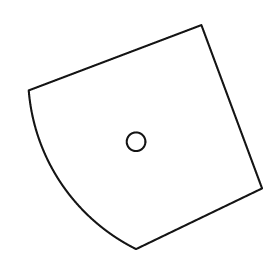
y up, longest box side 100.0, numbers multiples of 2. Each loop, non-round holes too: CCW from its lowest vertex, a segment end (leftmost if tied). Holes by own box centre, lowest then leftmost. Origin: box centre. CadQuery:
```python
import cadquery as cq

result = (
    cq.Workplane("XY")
    .moveTo(-4.0, -48.0)
    .lineTo(50.0, -22.0)
    .lineTo(24.0, 48.0)
    .lineTo(-50.0, 20.0)
    .threePointArc((-36.0, -20.0), (-4.0, -48.0))
    .close()
    .moveTo(-4.0, -2.0)
    .circle(4.0)
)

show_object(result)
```